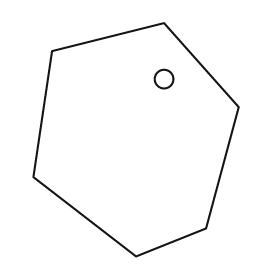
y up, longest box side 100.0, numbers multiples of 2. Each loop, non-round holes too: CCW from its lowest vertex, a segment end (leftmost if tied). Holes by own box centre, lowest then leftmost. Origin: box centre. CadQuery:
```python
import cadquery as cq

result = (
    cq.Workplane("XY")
    .moveTo(0.0, -50.0)
    .lineTo(30.0, -38.0)
    .lineTo(44.0, 14.0)
    .lineTo(12.0, 50.0)
    .lineTo(-36.0, 38.0)
    .lineTo(-44.0, -16.0)
    .close()
    .moveTo(12.0, 26.0)
    .circle(4.0)
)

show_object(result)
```